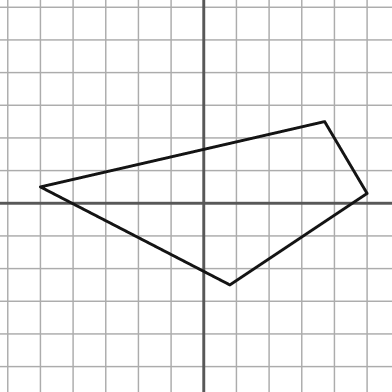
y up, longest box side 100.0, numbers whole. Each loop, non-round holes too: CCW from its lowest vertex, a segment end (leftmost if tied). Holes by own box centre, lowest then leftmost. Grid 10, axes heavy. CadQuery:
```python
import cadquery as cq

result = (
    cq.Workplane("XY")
    .moveTo(8.0, -25.0)
    .lineTo(50.0, 3.0)
    .lineTo(37.0, 25.0)
    .lineTo(-50.0, 5.0)
    .close()
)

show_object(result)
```